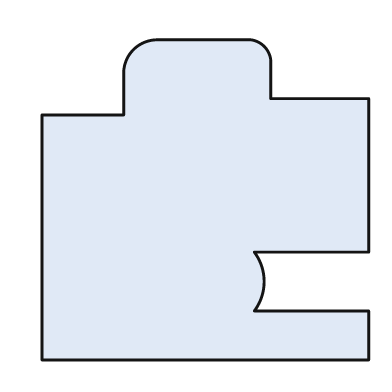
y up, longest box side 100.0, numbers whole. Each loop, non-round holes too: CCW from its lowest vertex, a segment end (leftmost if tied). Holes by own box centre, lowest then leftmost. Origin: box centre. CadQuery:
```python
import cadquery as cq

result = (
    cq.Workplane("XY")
    .moveTo(-50.0, -49.0)
    .lineTo(50.0, -49.0)
    .lineTo(50.0, -34.0)
    .lineTo(15.0, -34.0)
    .threePointArc((18.0, -25.0), (15.0, -16.0))
    .lineTo(50.0, -16.0)
    .lineTo(50.0, 31.0)
    .lineTo(20.0, 31.0)
    .lineTo(20.0, 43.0)
    .threePointArc((18.0, 47.0), (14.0, 49.0))
    .lineTo(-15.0, 49.0)
    .threePointArc((-22.0, 46.0), (-25.0, 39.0))
    .lineTo(-25.0, 26.0)
    .lineTo(-50.0, 26.0)
    .close()
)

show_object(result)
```